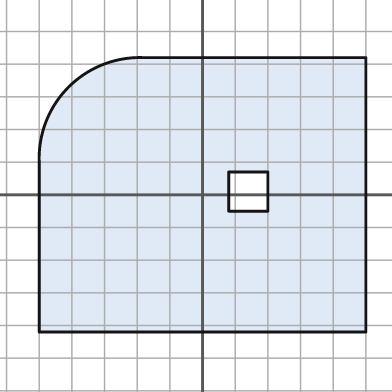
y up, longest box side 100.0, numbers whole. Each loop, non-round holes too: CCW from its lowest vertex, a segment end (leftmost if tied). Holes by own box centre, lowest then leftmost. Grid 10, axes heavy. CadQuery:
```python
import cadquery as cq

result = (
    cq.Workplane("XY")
    .moveTo(-50.0, -42.0)
    .lineTo(50.0, -42.0)
    .lineTo(50.0, 42.0)
    .lineTo(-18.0, 42.0)
    .threePointArc((-41.0, 33.0), (-50.0, 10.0))
    .close()
    .moveTo(8.0, -5.0)
    .lineTo(20.0, -5.0)
    .lineTo(20.0, 7.0)
    .lineTo(8.0, 7.0)
    .close()
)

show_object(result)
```